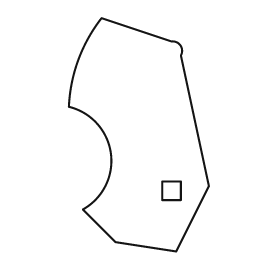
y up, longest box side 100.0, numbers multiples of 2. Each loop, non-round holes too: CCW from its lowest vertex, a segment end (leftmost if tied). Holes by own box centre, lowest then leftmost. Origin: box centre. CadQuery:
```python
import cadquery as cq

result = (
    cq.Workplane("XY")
    .moveTo(16.0, -50.0)
    .lineTo(30.0, -22.0)
    .lineTo(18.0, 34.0)
    .threePointArc((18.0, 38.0), (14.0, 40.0))
    .lineTo(-16.0, 50.0)
    .threePointArc((-26.0, 32.0), (-30.0, 12.0))
    .threePointArc((-12.0, -8.0), (-24.0, -32.0))
    .lineTo(-10.0, -46.0)
    .close()
    .moveTo(10.0, -28.0)
    .lineTo(18.0, -28.0)
    .lineTo(18.0, -20.0)
    .lineTo(10.0, -20.0)
    .close()
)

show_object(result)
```